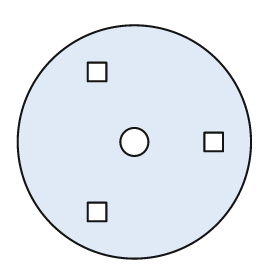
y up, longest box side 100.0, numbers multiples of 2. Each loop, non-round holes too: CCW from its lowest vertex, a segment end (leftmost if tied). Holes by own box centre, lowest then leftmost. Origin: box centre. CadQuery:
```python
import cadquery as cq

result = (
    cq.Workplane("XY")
    .moveTo(0.0, 0.0)
    .circle(50.0)
    .moveTo(-20.0, -34.0)
    .lineTo(-12.0, -34.0)
    .lineTo(-12.0, -26.0)
    .lineTo(-20.0, -26.0)
    .close()
    .moveTo(0.0, 0.0)
    .circle(6.0)
    .moveTo(30.0, -4.0)
    .lineTo(38.0, -4.0)
    .lineTo(38.0, 4.0)
    .lineTo(30.0, 4.0)
    .close()
    .moveTo(-20.0, 26.0)
    .lineTo(-12.0, 26.0)
    .lineTo(-12.0, 34.0)
    .lineTo(-20.0, 34.0)
    .close()
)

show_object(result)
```